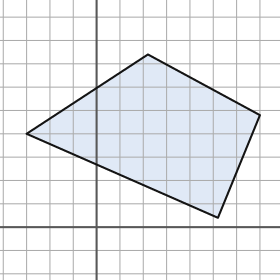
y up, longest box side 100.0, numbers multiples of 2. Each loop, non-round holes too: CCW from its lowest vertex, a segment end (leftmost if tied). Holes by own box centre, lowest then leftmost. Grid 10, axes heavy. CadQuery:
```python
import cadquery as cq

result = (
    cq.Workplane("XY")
    .moveTo(52.0, 4.0)
    .lineTo(70.0, 48.0)
    .lineTo(22.0, 74.0)
    .lineTo(-30.0, 40.0)
    .close()
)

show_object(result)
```